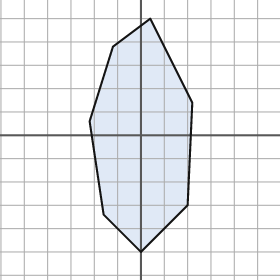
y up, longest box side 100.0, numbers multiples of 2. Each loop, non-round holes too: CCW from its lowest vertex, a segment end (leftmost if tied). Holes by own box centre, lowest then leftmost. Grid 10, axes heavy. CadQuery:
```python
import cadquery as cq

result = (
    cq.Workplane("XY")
    .moveTo(0.0, -50.0)
    .lineTo(20.0, -30.0)
    .lineTo(22.0, 14.0)
    .lineTo(4.0, 50.0)
    .lineTo(-12.0, 38.0)
    .lineTo(-22.0, 6.0)
    .lineTo(-16.0, -34.0)
    .close()
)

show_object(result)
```